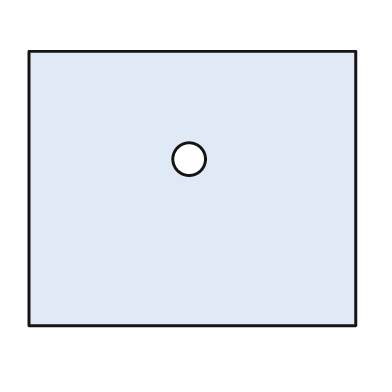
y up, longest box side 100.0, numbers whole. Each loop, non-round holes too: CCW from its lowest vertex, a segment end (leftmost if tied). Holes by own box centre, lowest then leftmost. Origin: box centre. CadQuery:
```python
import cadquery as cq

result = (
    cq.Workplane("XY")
    .moveTo(-50.0, -42.0)
    .lineTo(50.0, -42.0)
    .lineTo(50.0, 42.0)
    .lineTo(-50.0, 42.0)
    .close()
    .moveTo(-1.0, 9.0)
    .circle(5.0)
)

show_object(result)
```